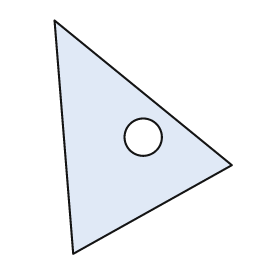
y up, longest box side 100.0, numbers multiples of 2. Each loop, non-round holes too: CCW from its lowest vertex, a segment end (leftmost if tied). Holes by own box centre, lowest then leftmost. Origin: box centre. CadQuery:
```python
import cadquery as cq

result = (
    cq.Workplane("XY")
    .moveTo(-30.0, -50.0)
    .lineTo(38.0, -12.0)
    .lineTo(-38.0, 50.0)
    .close()
    .moveTo(0.0, 0.0)
    .circle(8.0)
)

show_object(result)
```